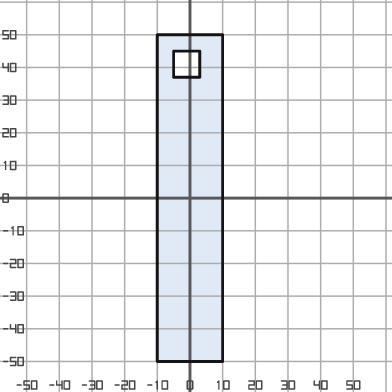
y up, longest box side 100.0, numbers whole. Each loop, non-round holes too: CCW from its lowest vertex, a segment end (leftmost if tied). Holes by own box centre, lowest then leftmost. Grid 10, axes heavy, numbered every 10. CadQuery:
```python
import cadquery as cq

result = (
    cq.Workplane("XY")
    .moveTo(-10.0, -50.0)
    .lineTo(10.0, -50.0)
    .lineTo(10.0, 50.0)
    .lineTo(-10.0, 50.0)
    .close()
    .moveTo(-5.0, 37.0)
    .lineTo(3.0, 37.0)
    .lineTo(3.0, 45.0)
    .lineTo(-5.0, 45.0)
    .close()
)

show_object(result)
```